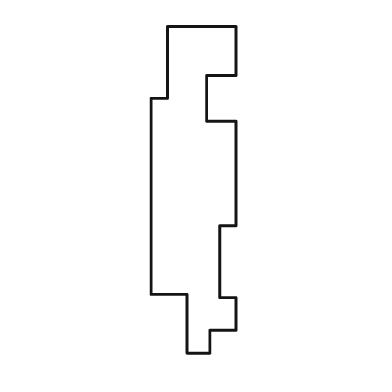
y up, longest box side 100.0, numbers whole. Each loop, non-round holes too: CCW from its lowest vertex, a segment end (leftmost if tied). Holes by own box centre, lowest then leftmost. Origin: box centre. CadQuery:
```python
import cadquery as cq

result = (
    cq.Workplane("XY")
    .moveTo(-2.0, -50.0)
    .lineTo(5.0, -50.0)
    .lineTo(5.0, -43.0)
    .lineTo(13.0, -43.0)
    .lineTo(13.0, -33.0)
    .lineTo(8.0, -33.0)
    .lineTo(8.0, -11.0)
    .lineTo(13.0, -11.0)
    .lineTo(13.0, 21.0)
    .lineTo(4.0, 21.0)
    .lineTo(4.0, 35.0)
    .lineTo(13.0, 35.0)
    .lineTo(13.0, 50.0)
    .lineTo(-8.0, 50.0)
    .lineTo(-8.0, 28.0)
    .lineTo(-13.0, 28.0)
    .lineTo(-13.0, -32.0)
    .lineTo(-2.0, -32.0)
    .close()
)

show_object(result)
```